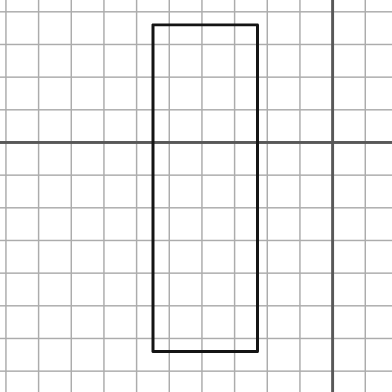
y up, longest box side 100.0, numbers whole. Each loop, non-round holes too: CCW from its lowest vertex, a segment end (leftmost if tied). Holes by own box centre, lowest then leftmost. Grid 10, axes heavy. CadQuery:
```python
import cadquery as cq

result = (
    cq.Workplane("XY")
    .moveTo(-55.0, -64.0)
    .lineTo(-23.0, -64.0)
    .lineTo(-23.0, 36.0)
    .lineTo(-55.0, 36.0)
    .close()
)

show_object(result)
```